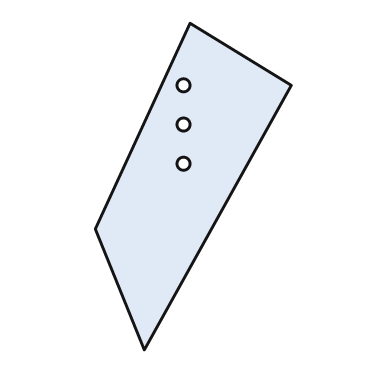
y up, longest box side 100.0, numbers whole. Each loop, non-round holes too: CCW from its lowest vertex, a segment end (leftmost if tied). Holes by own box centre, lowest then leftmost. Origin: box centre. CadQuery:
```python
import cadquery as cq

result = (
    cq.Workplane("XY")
    .moveTo(-15.0, -50.0)
    .lineTo(30.0, 31.0)
    .lineTo(-1.0, 50.0)
    .lineTo(-30.0, -13.0)
    .close()
    .moveTo(-3.0, 7.0)
    .circle(2.0)
    .moveTo(-3.0, 19.0)
    .circle(2.0)
    .moveTo(-3.0, 31.0)
    .circle(2.0)
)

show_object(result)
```